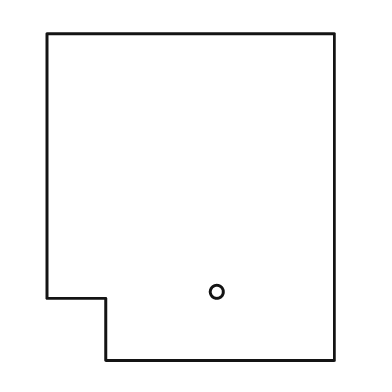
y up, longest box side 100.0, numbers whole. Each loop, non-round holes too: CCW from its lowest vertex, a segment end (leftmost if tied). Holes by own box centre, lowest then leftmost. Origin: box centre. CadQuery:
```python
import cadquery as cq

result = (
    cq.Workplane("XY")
    .moveTo(-26.0, -50.0)
    .lineTo(44.0, -50.0)
    .lineTo(44.0, 50.0)
    .lineTo(-44.0, 50.0)
    .lineTo(-44.0, -31.0)
    .lineTo(-26.0, -31.0)
    .close()
    .moveTo(8.0, -29.0)
    .circle(2.0)
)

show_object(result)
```